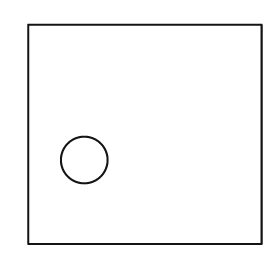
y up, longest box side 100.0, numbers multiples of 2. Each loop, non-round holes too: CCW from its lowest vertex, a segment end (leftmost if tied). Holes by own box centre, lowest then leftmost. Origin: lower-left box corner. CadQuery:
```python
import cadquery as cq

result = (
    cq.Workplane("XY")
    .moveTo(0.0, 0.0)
    .lineTo(100.0, 0.0)
    .lineTo(100.0, 94.0)
    .lineTo(0.0, 94.0)
    .close()
    .moveTo(24.0, 36.0)
    .circle(10.0)
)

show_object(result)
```